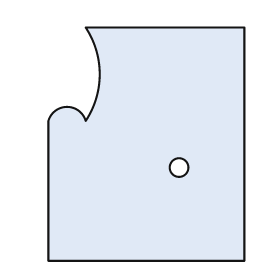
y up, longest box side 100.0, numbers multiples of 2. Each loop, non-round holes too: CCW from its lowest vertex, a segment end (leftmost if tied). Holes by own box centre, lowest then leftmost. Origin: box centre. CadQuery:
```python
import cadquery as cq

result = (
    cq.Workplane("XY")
    .moveTo(-42.0, -50.0)
    .lineTo(42.0, -50.0)
    .lineTo(42.0, 50.0)
    .lineTo(-26.0, 50.0)
    .threePointArc((-20.0, 30.0), (-26.0, 10.0))
    .threePointArc((-34.0, 16.0), (-42.0, 10.0))
    .close()
    .moveTo(14.0, -10.0)
    .circle(4.0)
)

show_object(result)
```